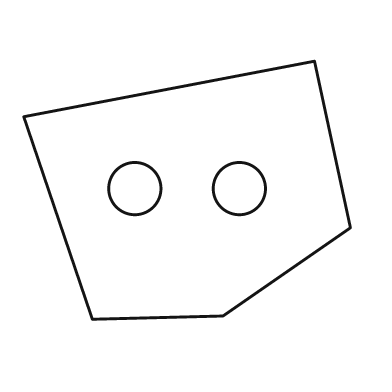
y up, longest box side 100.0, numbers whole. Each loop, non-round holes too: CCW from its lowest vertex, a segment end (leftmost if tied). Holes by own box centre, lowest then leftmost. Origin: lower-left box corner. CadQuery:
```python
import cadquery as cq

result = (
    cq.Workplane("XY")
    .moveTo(21.0, 0.0)
    .lineTo(61.0, 1.0)
    .lineTo(100.0, 28.0)
    .lineTo(89.0, 79.0)
    .lineTo(0.0, 62.0)
    .close()
    .moveTo(34.0, 40.0)
    .circle(8.0)
    .moveTo(66.0, 40.0)
    .circle(8.0)
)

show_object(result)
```